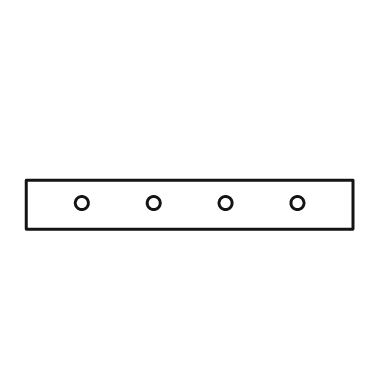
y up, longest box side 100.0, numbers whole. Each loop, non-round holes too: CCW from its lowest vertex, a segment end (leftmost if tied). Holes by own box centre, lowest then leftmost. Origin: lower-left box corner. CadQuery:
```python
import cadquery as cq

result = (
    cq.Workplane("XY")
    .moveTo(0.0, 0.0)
    .lineTo(100.0, 0.0)
    .lineTo(100.0, 15.0)
    .lineTo(0.0, 15.0)
    .close()
    .moveTo(17.0, 8.0)
    .circle(2.0)
    .moveTo(39.0, 8.0)
    .circle(2.0)
    .moveTo(61.0, 8.0)
    .circle(2.0)
    .moveTo(83.0, 8.0)
    .circle(2.0)
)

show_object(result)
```